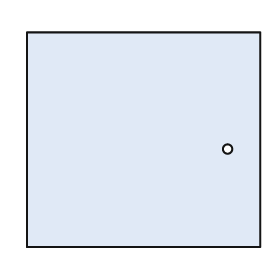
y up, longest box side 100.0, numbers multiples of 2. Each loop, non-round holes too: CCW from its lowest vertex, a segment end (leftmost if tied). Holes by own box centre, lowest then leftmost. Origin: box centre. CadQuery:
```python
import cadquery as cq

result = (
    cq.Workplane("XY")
    .moveTo(-50.0, -46.0)
    .lineTo(50.0, -46.0)
    .lineTo(50.0, 46.0)
    .lineTo(-50.0, 46.0)
    .close()
    .moveTo(36.0, -4.0)
    .circle(2.0)
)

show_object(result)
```